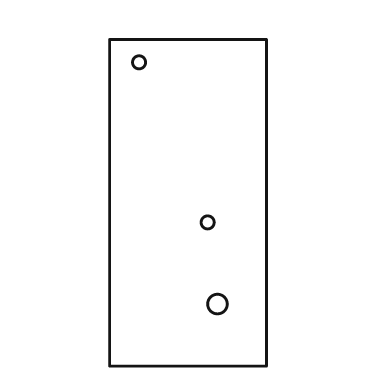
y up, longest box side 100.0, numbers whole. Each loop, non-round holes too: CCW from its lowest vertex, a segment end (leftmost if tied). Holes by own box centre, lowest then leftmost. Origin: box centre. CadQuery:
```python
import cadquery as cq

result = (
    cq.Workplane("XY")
    .moveTo(-24.0, -50.0)
    .lineTo(24.0, -50.0)
    .lineTo(24.0, 50.0)
    .lineTo(-24.0, 50.0)
    .close()
    .moveTo(9.0, -31.0)
    .circle(3.0)
    .moveTo(6.0, -6.0)
    .circle(2.0)
    .moveTo(-15.0, 43.0)
    .circle(2.0)
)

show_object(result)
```